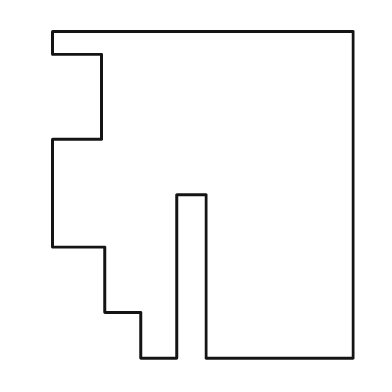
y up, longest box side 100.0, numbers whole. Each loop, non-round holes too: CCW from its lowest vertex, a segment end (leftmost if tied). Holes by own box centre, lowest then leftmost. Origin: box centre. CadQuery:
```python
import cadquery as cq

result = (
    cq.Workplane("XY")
    .moveTo(-19.0, -50.0)
    .lineTo(-8.0, -50.0)
    .lineTo(-8.0, 0.0)
    .lineTo(1.0, 0.0)
    .lineTo(1.0, -50.0)
    .lineTo(46.0, -50.0)
    .lineTo(46.0, 50.0)
    .lineTo(-46.0, 50.0)
    .lineTo(-46.0, 43.0)
    .lineTo(-31.0, 43.0)
    .lineTo(-31.0, 17.0)
    .lineTo(-46.0, 17.0)
    .lineTo(-46.0, -16.0)
    .lineTo(-30.0, -16.0)
    .lineTo(-30.0, -36.0)
    .lineTo(-19.0, -36.0)
    .close()
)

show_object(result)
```